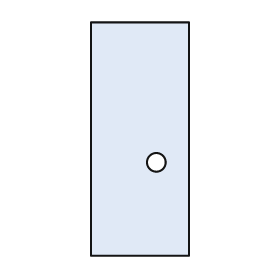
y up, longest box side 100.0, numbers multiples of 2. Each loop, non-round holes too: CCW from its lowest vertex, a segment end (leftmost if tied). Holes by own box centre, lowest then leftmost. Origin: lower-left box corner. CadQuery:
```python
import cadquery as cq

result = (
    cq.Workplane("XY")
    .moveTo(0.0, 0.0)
    .lineTo(42.0, 0.0)
    .lineTo(42.0, 100.0)
    .lineTo(0.0, 100.0)
    .close()
    .moveTo(28.0, 40.0)
    .circle(4.0)
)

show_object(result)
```